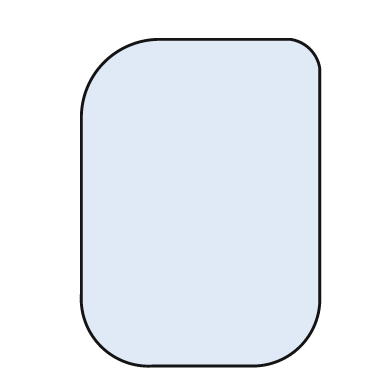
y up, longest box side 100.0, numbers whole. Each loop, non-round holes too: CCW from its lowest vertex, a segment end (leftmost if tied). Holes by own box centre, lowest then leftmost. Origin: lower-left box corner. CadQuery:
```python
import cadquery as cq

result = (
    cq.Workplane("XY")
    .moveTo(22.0, 0.0)
    .lineTo(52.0, 0.0)
    .threePointArc((67.0, 6.0), (73.0, 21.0))
    .lineTo(73.0, 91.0)
    .threePointArc((70.0, 97.0), (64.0, 100.0))
    .lineTo(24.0, 100.0)
    .threePointArc((7.0, 93.0), (0.0, 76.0))
    .lineTo(0.0, 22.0)
    .threePointArc((6.0, 6.0), (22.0, 0.0))
    .close()
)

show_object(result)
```